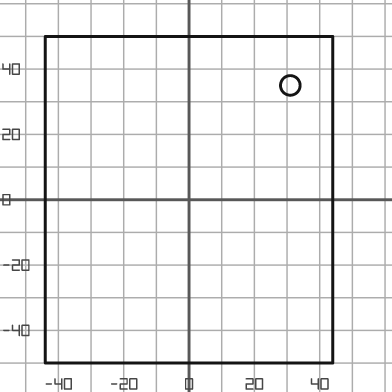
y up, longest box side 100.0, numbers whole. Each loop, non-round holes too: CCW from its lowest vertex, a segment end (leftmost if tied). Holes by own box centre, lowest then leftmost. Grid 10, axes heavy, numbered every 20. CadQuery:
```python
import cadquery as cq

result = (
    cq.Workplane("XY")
    .moveTo(-44.0, -50.0)
    .lineTo(44.0, -50.0)
    .lineTo(44.0, 50.0)
    .lineTo(-44.0, 50.0)
    .close()
    .moveTo(31.0, 35.0)
    .circle(3.0)
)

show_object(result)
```